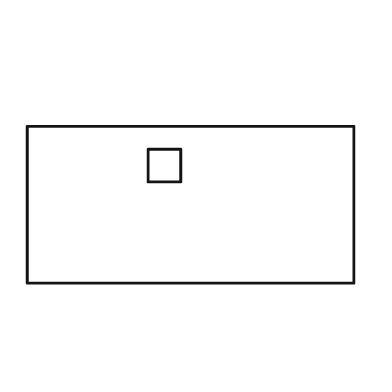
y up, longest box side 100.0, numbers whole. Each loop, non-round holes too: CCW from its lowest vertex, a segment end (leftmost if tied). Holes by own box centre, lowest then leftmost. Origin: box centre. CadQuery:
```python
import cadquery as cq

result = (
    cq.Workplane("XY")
    .moveTo(-50.0, -24.0)
    .lineTo(50.0, -24.0)
    .lineTo(50.0, 24.0)
    .lineTo(-50.0, 24.0)
    .close()
    .moveTo(-13.0, 7.0)
    .lineTo(-3.0, 7.0)
    .lineTo(-3.0, 17.0)
    .lineTo(-13.0, 17.0)
    .close()
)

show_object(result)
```